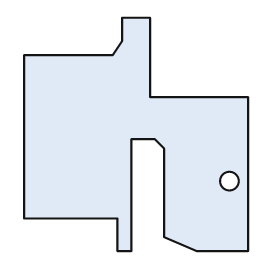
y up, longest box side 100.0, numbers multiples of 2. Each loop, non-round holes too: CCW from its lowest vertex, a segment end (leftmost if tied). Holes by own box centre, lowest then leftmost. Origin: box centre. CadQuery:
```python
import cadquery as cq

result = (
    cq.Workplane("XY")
    .moveTo(-8.0, -50.0)
    .lineTo(-2.0, -50.0)
    .lineTo(-2.0, -2.0)
    .lineTo(8.0, -2.0)
    .lineTo(12.0, -6.0)
    .lineTo(12.0, -44.0)
    .lineTo(26.0, -50.0)
    .lineTo(48.0, -50.0)
    .lineTo(48.0, 16.0)
    .lineTo(6.0, 16.0)
    .lineTo(6.0, 50.0)
    .lineTo(-6.0, 50.0)
    .lineTo(-6.0, 40.0)
    .lineTo(-10.0, 34.0)
    .lineTo(-48.0, 34.0)
    .lineTo(-48.0, -36.0)
    .lineTo(-8.0, -36.0)
    .close()
    .moveTo(40.0, -20.0)
    .circle(4.0)
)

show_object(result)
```